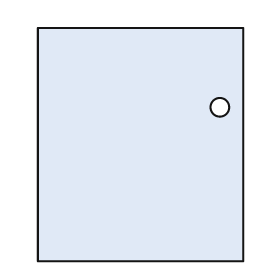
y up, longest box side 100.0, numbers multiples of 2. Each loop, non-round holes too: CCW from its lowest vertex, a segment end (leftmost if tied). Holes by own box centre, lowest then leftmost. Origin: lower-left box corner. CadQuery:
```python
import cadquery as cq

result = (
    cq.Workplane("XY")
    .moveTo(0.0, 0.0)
    .lineTo(88.0, 0.0)
    .lineTo(88.0, 100.0)
    .lineTo(0.0, 100.0)
    .close()
    .moveTo(78.0, 66.0)
    .circle(4.0)
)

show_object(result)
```